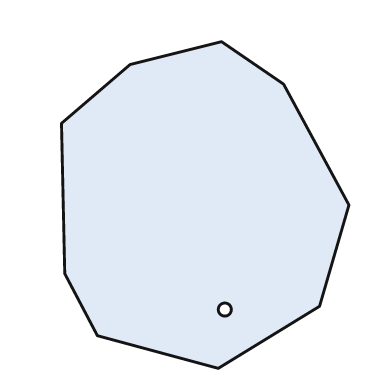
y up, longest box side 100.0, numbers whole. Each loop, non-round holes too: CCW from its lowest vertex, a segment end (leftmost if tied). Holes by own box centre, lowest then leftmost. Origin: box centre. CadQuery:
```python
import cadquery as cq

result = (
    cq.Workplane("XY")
    .moveTo(4.0, -50.0)
    .lineTo(35.0, -31.0)
    .lineTo(44.0, 0.0)
    .lineTo(24.0, 37.0)
    .lineTo(5.0, 50.0)
    .lineTo(-23.0, 43.0)
    .lineTo(-44.0, 25.0)
    .lineTo(-43.0, -21.0)
    .lineTo(-33.0, -40.0)
    .close()
    .moveTo(6.0, -32.0)
    .circle(2.0)
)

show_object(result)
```